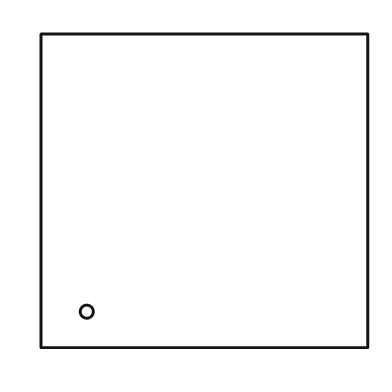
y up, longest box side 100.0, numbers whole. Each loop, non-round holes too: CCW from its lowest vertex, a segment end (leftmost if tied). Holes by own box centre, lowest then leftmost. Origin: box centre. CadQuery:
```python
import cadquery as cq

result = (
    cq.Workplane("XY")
    .moveTo(-50.0, -48.0)
    .lineTo(50.0, -48.0)
    .lineTo(50.0, 48.0)
    .lineTo(-50.0, 48.0)
    .close()
    .moveTo(-36.0, -37.0)
    .circle(2.0)
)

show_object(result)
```